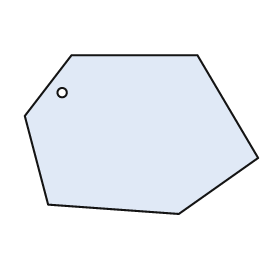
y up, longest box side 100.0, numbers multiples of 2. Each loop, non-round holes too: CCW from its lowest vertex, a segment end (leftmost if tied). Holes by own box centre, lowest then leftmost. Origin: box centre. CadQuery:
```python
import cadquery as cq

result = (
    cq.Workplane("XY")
    .moveTo(16.0, -34.0)
    .lineTo(50.0, -10.0)
    .lineTo(24.0, 34.0)
    .lineTo(-30.0, 34.0)
    .lineTo(-50.0, 8.0)
    .lineTo(-40.0, -30.0)
    .close()
    .moveTo(-34.0, 18.0)
    .circle(2.0)
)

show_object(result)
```